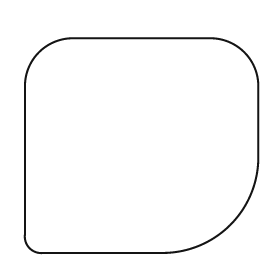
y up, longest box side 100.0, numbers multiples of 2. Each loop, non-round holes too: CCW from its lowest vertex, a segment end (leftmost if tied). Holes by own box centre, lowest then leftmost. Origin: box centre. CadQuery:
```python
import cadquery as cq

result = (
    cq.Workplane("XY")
    .moveTo(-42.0, -46.0)
    .lineTo(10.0, -46.0)
    .threePointArc((38.0, -34.0), (50.0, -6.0))
    .lineTo(50.0, 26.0)
    .threePointArc((44.0, 40.0), (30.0, 46.0))
    .lineTo(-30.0, 46.0)
    .threePointArc((-44.0, 40.0), (-50.0, 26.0))
    .lineTo(-50.0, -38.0)
    .threePointArc((-48.0, -44.0), (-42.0, -46.0))
    .close()
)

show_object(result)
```